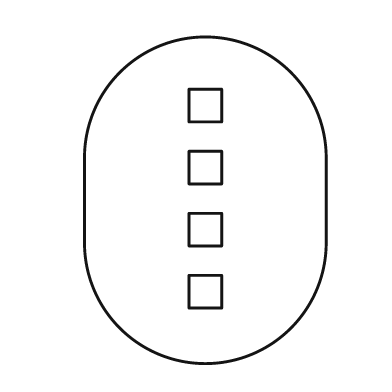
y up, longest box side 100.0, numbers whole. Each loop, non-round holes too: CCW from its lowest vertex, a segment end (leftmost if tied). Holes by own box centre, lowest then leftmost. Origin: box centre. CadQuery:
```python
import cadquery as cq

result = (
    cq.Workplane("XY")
    .moveTo(-37.0, -13.0)
    .threePointArc((0.0, -50.0), (37.0, -13.0))
    .lineTo(37.0, 13.0)
    .threePointArc((0.0, 50.0), (-37.0, 13.0))
    .close()
    .moveTo(-5.0, -33.0)
    .lineTo(5.0, -33.0)
    .lineTo(5.0, -23.0)
    .lineTo(-5.0, -23.0)
    .close()
    .moveTo(-5.0, -14.0)
    .lineTo(5.0, -14.0)
    .lineTo(5.0, -4.0)
    .lineTo(-5.0, -4.0)
    .close()
    .moveTo(-5.0, 5.0)
    .lineTo(5.0, 5.0)
    .lineTo(5.0, 15.0)
    .lineTo(-5.0, 15.0)
    .close()
    .moveTo(-5.0, 24.0)
    .lineTo(5.0, 24.0)
    .lineTo(5.0, 34.0)
    .lineTo(-5.0, 34.0)
    .close()
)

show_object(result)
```